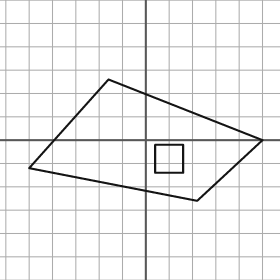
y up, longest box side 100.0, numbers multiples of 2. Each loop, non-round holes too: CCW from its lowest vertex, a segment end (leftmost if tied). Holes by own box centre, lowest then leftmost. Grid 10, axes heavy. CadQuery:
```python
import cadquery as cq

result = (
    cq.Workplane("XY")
    .moveTo(22.0, -26.0)
    .lineTo(50.0, 0.0)
    .lineTo(-16.0, 26.0)
    .lineTo(-50.0, -12.0)
    .close()
    .moveTo(4.0, -14.0)
    .lineTo(16.0, -14.0)
    .lineTo(16.0, -2.0)
    .lineTo(4.0, -2.0)
    .close()
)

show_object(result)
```